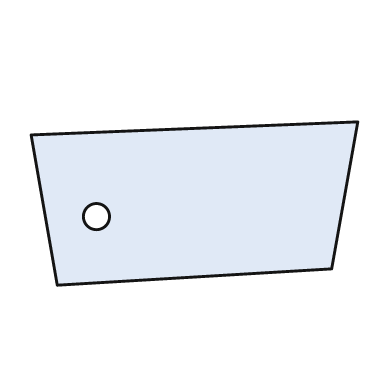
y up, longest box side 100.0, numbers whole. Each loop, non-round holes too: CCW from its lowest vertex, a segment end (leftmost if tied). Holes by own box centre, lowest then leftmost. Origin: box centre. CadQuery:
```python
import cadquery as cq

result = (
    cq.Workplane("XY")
    .moveTo(-42.0, -25.0)
    .lineTo(42.0, -20.0)
    .lineTo(50.0, 25.0)
    .lineTo(-50.0, 21.0)
    .close()
    .moveTo(-30.0, -4.0)
    .circle(4.0)
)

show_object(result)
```